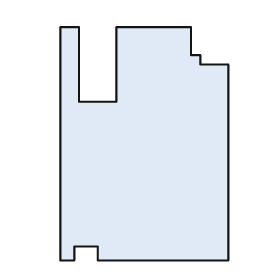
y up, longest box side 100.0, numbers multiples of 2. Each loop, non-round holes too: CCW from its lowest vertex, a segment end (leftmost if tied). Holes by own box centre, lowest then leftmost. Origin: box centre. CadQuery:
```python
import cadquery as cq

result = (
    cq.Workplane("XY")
    .moveTo(-36.0, -50.0)
    .lineTo(-30.0, -50.0)
    .lineTo(-30.0, -44.0)
    .lineTo(-20.0, -44.0)
    .lineTo(-20.0, -50.0)
    .lineTo(36.0, -50.0)
    .lineTo(36.0, 34.0)
    .lineTo(24.0, 34.0)
    .lineTo(24.0, 38.0)
    .lineTo(20.0, 38.0)
    .lineTo(20.0, 50.0)
    .lineTo(-12.0, 50.0)
    .lineTo(-12.0, 18.0)
    .lineTo(-28.0, 18.0)
    .lineTo(-28.0, 50.0)
    .lineTo(-36.0, 50.0)
    .close()
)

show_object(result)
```